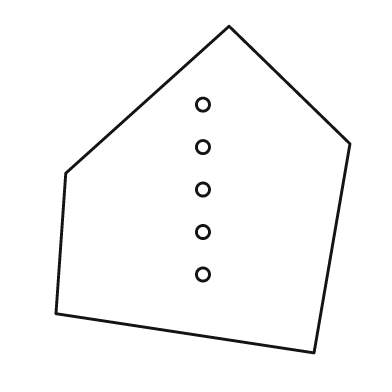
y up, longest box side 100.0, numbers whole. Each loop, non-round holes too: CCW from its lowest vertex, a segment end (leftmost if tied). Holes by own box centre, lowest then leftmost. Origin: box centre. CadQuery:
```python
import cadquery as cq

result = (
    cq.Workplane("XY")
    .moveTo(34.0, -50.0)
    .lineTo(45.0, 14.0)
    .lineTo(8.0, 50.0)
    .lineTo(-42.0, 5.0)
    .lineTo(-45.0, -38.0)
    .close()
    .moveTo(0.0, -26.0)
    .circle(2.0)
    .moveTo(0.0, -13.0)
    .circle(2.0)
    .moveTo(0.0, 0.0)
    .circle(2.0)
    .moveTo(0.0, 13.0)
    .circle(2.0)
    .moveTo(0.0, 26.0)
    .circle(2.0)
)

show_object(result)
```